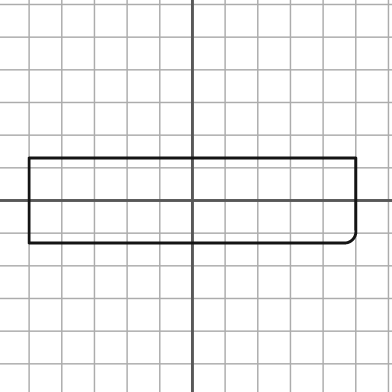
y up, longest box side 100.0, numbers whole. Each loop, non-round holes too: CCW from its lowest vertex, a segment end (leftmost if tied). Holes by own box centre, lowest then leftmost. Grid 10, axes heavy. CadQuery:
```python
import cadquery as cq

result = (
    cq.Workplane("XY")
    .moveTo(-50.0, -13.0)
    .lineTo(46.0, -13.0)
    .threePointArc((49.0, -12.0), (50.0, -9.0))
    .lineTo(50.0, 13.0)
    .lineTo(-50.0, 13.0)
    .close()
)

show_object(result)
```